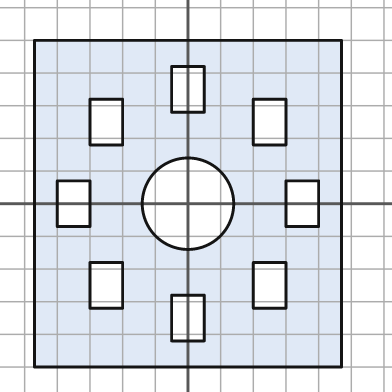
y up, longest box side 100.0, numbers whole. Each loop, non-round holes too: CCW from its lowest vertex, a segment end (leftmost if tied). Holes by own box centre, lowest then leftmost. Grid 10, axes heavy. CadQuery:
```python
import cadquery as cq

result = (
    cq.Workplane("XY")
    .moveTo(-47.0, -50.0)
    .lineTo(47.0, -50.0)
    .lineTo(47.0, 50.0)
    .lineTo(-47.0, 50.0)
    .close()
    .moveTo(-5.0, -42.0)
    .lineTo(5.0, -42.0)
    .lineTo(5.0, -28.0)
    .lineTo(-5.0, -28.0)
    .close()
    .moveTo(-30.0, -32.0)
    .lineTo(-20.0, -32.0)
    .lineTo(-20.0, -18.0)
    .lineTo(-30.0, -18.0)
    .close()
    .moveTo(20.0, -32.0)
    .lineTo(30.0, -32.0)
    .lineTo(30.0, -18.0)
    .lineTo(20.0, -18.0)
    .close()
    .moveTo(-40.0, -7.0)
    .lineTo(-30.0, -7.0)
    .lineTo(-30.0, 7.0)
    .lineTo(-40.0, 7.0)
    .close()
    .moveTo(0.0, 0.0)
    .circle(14.0)
    .moveTo(30.0, -7.0)
    .lineTo(40.0, -7.0)
    .lineTo(40.0, 7.0)
    .lineTo(30.0, 7.0)
    .close()
    .moveTo(-30.0, 18.0)
    .lineTo(-20.0, 18.0)
    .lineTo(-20.0, 32.0)
    .lineTo(-30.0, 32.0)
    .close()
    .moveTo(20.0, 18.0)
    .lineTo(30.0, 18.0)
    .lineTo(30.0, 32.0)
    .lineTo(20.0, 32.0)
    .close()
    .moveTo(-5.0, 28.0)
    .lineTo(5.0, 28.0)
    .lineTo(5.0, 42.0)
    .lineTo(-5.0, 42.0)
    .close()
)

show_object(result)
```